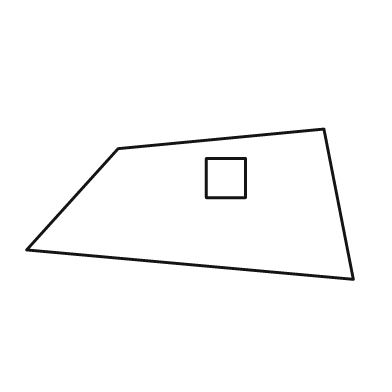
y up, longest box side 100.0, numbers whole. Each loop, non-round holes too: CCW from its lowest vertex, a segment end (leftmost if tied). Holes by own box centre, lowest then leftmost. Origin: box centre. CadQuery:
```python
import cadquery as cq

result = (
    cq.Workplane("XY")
    .moveTo(50.0, -23.0)
    .lineTo(41.0, 23.0)
    .lineTo(-22.0, 17.0)
    .lineTo(-50.0, -14.0)
    .close()
    .moveTo(5.0, 2.0)
    .lineTo(17.0, 2.0)
    .lineTo(17.0, 14.0)
    .lineTo(5.0, 14.0)
    .close()
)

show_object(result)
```